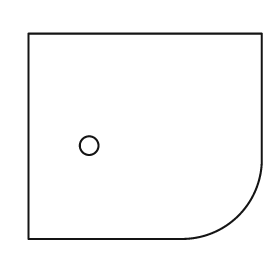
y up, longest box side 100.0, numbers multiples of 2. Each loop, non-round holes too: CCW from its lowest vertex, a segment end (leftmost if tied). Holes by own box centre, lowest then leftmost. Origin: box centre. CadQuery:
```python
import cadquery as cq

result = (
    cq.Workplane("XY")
    .moveTo(-50.0, -44.0)
    .lineTo(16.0, -44.0)
    .threePointArc((40.0, -34.0), (50.0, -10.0))
    .lineTo(50.0, 44.0)
    .lineTo(-50.0, 44.0)
    .close()
    .moveTo(-24.0, -4.0)
    .circle(4.0)
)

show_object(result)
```